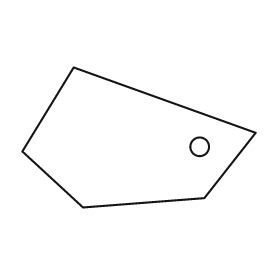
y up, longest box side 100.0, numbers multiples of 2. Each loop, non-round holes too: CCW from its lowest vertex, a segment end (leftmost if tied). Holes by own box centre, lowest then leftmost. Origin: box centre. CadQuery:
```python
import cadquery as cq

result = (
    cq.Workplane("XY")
    .moveTo(-24.0, -30.0)
    .lineTo(28.0, -26.0)
    .lineTo(50.0, 2.0)
    .lineTo(-28.0, 30.0)
    .lineTo(-50.0, -6.0)
    .close()
    .moveTo(26.0, -4.0)
    .circle(4.0)
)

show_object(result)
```